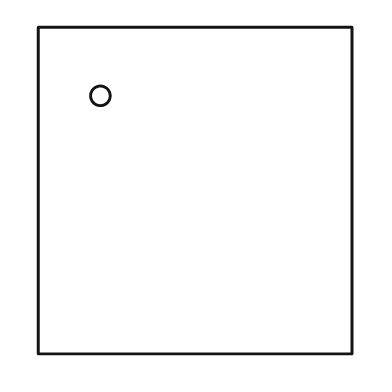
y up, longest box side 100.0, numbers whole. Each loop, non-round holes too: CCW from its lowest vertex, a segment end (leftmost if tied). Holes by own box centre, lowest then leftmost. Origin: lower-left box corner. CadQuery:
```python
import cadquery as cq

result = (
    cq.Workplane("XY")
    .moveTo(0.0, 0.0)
    .lineTo(96.0, 0.0)
    .lineTo(96.0, 100.0)
    .lineTo(0.0, 100.0)
    .close()
    .moveTo(19.0, 79.0)
    .circle(3.0)
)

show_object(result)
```